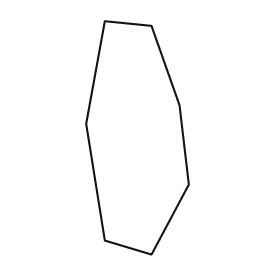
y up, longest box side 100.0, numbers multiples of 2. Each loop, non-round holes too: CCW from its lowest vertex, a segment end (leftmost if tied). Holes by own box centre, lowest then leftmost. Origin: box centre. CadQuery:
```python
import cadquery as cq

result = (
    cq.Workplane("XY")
    .moveTo(6.0, -50.0)
    .lineTo(22.0, -20.0)
    .lineTo(18.0, 14.0)
    .lineTo(6.0, 48.0)
    .lineTo(-14.0, 50.0)
    .lineTo(-22.0, 6.0)
    .lineTo(-14.0, -44.0)
    .close()
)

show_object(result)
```